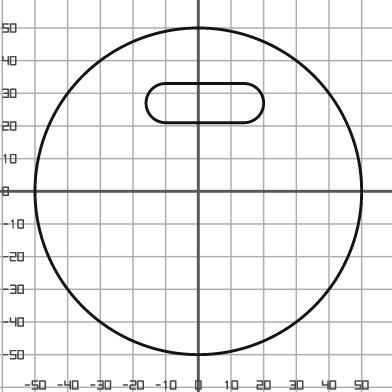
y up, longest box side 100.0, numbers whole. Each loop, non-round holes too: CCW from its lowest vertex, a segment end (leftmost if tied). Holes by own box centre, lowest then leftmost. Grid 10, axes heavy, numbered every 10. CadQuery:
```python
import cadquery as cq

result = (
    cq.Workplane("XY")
    .moveTo(0.0, 0.0)
    .circle(50.0)
    .moveTo(-10.0, 21.0)
    .lineTo(14.0, 21.0)
    .threePointArc((20.0, 27.0), (14.0, 33.0))
    .lineTo(-10.0, 33.0)
    .threePointArc((-16.0, 27.0), (-10.0, 21.0))
    .close()
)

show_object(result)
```